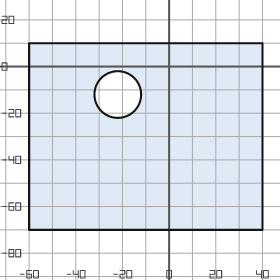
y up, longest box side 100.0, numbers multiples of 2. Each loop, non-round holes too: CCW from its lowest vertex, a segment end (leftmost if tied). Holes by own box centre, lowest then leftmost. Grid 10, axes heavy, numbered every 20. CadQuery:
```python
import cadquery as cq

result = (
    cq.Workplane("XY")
    .moveTo(-60.0, -70.0)
    .lineTo(40.0, -70.0)
    .lineTo(40.0, 10.0)
    .lineTo(-60.0, 10.0)
    .close()
    .moveTo(-22.0, -12.0)
    .circle(10.0)
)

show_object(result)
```